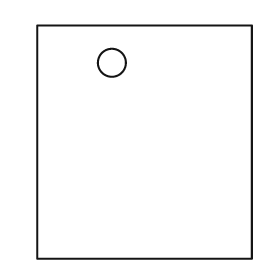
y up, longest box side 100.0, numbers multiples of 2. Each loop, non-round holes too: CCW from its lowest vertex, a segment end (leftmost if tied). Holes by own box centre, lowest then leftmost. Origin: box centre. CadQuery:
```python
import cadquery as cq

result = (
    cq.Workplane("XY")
    .moveTo(-46.0, -50.0)
    .lineTo(46.0, -50.0)
    .lineTo(46.0, 50.0)
    .lineTo(-46.0, 50.0)
    .close()
    .moveTo(-14.0, 34.0)
    .circle(6.0)
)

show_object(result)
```